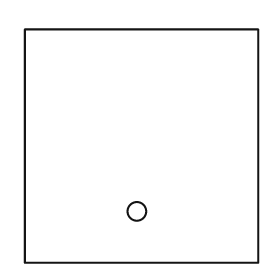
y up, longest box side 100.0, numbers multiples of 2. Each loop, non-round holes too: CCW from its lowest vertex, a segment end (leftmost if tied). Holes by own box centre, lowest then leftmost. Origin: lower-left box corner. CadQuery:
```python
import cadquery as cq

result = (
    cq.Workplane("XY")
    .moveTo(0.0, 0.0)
    .lineTo(100.0, 0.0)
    .lineTo(100.0, 100.0)
    .lineTo(0.0, 100.0)
    .close()
    .moveTo(48.0, 22.0)
    .circle(4.0)
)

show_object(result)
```